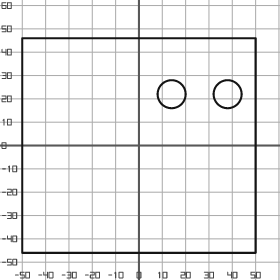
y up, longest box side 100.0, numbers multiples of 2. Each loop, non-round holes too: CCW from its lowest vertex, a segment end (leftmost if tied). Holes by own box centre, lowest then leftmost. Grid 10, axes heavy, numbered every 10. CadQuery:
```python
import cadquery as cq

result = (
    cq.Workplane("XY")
    .moveTo(-50.0, -46.0)
    .lineTo(50.0, -46.0)
    .lineTo(50.0, 46.0)
    .lineTo(-50.0, 46.0)
    .close()
    .moveTo(14.0, 22.0)
    .circle(6.0)
    .moveTo(38.0, 22.0)
    .circle(6.0)
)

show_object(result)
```